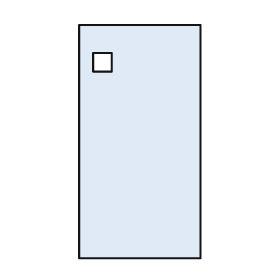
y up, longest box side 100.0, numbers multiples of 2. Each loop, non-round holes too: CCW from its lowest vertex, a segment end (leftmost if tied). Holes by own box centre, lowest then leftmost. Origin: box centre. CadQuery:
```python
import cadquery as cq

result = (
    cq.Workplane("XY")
    .moveTo(-26.0, -50.0)
    .lineTo(26.0, -50.0)
    .lineTo(26.0, 50.0)
    .lineTo(-26.0, 50.0)
    .close()
    .moveTo(-20.0, 30.0)
    .lineTo(-12.0, 30.0)
    .lineTo(-12.0, 38.0)
    .lineTo(-20.0, 38.0)
    .close()
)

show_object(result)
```